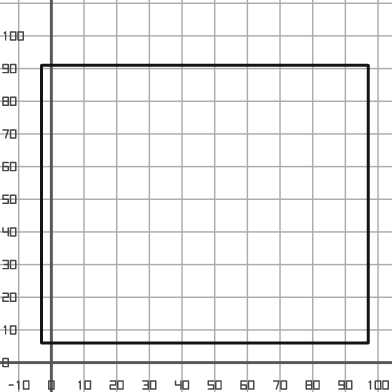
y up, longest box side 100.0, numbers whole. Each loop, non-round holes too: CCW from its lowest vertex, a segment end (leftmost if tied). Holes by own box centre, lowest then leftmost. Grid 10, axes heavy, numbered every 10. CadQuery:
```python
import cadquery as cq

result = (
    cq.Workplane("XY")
    .moveTo(-3.0, 6.0)
    .lineTo(97.0, 6.0)
    .lineTo(97.0, 91.0)
    .lineTo(-3.0, 91.0)
    .close()
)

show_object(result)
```